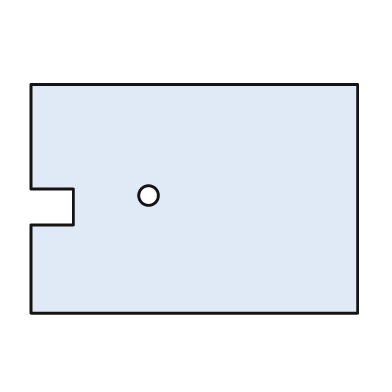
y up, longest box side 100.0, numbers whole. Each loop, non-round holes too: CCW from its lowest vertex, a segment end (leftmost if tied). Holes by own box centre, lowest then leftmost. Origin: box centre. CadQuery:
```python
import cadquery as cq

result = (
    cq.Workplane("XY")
    .moveTo(-50.0, -35.0)
    .lineTo(50.0, -35.0)
    .lineTo(50.0, 35.0)
    .lineTo(-50.0, 35.0)
    .lineTo(-50.0, 3.0)
    .lineTo(-37.0, 3.0)
    .lineTo(-37.0, -8.0)
    .lineTo(-50.0, -8.0)
    .close()
    .moveTo(-14.0, 1.0)
    .circle(3.0)
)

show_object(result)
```